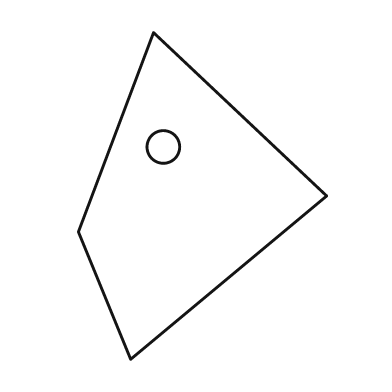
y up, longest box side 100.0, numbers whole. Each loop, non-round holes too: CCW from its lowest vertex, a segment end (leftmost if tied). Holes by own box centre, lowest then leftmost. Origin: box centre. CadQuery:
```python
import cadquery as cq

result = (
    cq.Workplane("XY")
    .moveTo(-22.0, -50.0)
    .lineTo(38.0, 0.0)
    .lineTo(-15.0, 50.0)
    .lineTo(-38.0, -11.0)
    .close()
    .moveTo(-12.0, 15.0)
    .circle(5.0)
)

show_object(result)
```